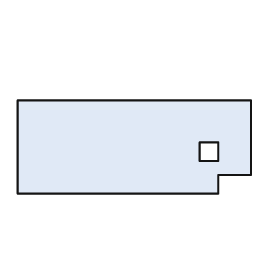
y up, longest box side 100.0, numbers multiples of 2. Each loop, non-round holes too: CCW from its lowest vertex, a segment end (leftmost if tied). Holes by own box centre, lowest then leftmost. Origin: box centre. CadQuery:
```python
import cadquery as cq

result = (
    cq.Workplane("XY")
    .moveTo(-50.0, -20.0)
    .lineTo(36.0, -20.0)
    .lineTo(36.0, -12.0)
    .lineTo(50.0, -12.0)
    .lineTo(50.0, 20.0)
    .lineTo(-50.0, 20.0)
    .close()
    .moveTo(28.0, -6.0)
    .lineTo(36.0, -6.0)
    .lineTo(36.0, 2.0)
    .lineTo(28.0, 2.0)
    .close()
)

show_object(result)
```